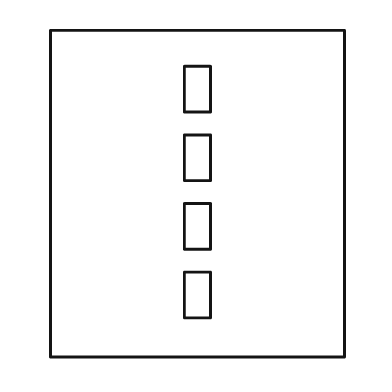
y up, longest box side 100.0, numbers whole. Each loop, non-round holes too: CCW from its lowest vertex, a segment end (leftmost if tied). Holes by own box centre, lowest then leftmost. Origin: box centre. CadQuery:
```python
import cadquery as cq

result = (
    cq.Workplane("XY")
    .moveTo(-45.0, -50.0)
    .lineTo(45.0, -50.0)
    .lineTo(45.0, 50.0)
    .lineTo(-45.0, 50.0)
    .close()
    .moveTo(-4.0, -38.0)
    .lineTo(4.0, -38.0)
    .lineTo(4.0, -24.0)
    .lineTo(-4.0, -24.0)
    .close()
    .moveTo(-4.0, -17.0)
    .lineTo(4.0, -17.0)
    .lineTo(4.0, -3.0)
    .lineTo(-4.0, -3.0)
    .close()
    .moveTo(-4.0, 4.0)
    .lineTo(4.0, 4.0)
    .lineTo(4.0, 18.0)
    .lineTo(-4.0, 18.0)
    .close()
    .moveTo(-4.0, 25.0)
    .lineTo(4.0, 25.0)
    .lineTo(4.0, 39.0)
    .lineTo(-4.0, 39.0)
    .close()
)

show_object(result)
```